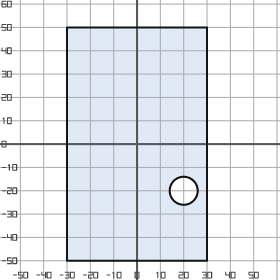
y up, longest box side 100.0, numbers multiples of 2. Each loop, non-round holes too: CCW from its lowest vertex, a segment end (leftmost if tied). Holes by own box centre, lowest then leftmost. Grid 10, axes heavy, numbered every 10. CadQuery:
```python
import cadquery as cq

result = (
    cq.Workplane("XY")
    .moveTo(-30.0, -50.0)
    .lineTo(30.0, -50.0)
    .lineTo(30.0, 50.0)
    .lineTo(-30.0, 50.0)
    .close()
    .moveTo(20.0, -20.0)
    .circle(6.0)
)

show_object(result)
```